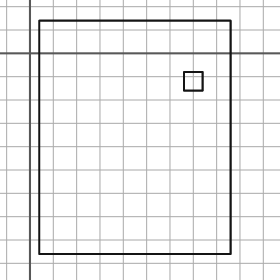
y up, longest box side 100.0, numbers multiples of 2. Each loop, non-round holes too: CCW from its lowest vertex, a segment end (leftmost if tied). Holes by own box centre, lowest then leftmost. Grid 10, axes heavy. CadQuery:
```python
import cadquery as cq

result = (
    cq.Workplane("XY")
    .moveTo(4.0, -86.0)
    .lineTo(86.0, -86.0)
    .lineTo(86.0, 14.0)
    .lineTo(4.0, 14.0)
    .close()
    .moveTo(66.0, -16.0)
    .lineTo(74.0, -16.0)
    .lineTo(74.0, -8.0)
    .lineTo(66.0, -8.0)
    .close()
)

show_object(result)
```